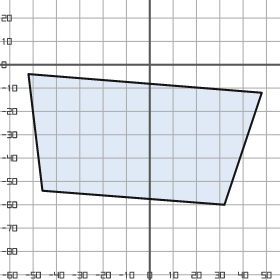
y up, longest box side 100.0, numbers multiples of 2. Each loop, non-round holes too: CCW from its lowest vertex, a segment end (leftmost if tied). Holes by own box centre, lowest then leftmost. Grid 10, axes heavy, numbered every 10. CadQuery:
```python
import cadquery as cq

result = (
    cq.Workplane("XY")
    .moveTo(32.0, -60.0)
    .lineTo(48.0, -12.0)
    .lineTo(-52.0, -4.0)
    .lineTo(-46.0, -54.0)
    .close()
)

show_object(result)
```